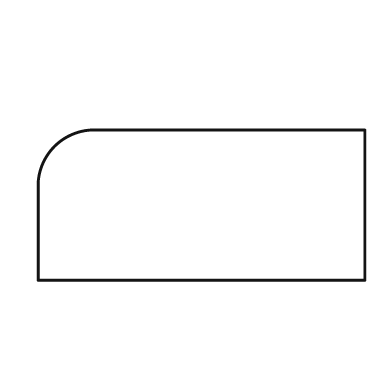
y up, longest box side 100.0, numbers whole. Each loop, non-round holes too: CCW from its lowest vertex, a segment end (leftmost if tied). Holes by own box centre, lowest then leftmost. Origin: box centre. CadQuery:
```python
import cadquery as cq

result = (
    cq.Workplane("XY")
    .moveTo(-50.0, -23.0)
    .lineTo(50.0, -23.0)
    .lineTo(50.0, 23.0)
    .lineTo(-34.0, 23.0)
    .threePointArc((-45.0, 18.0), (-50.0, 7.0))
    .close()
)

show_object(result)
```